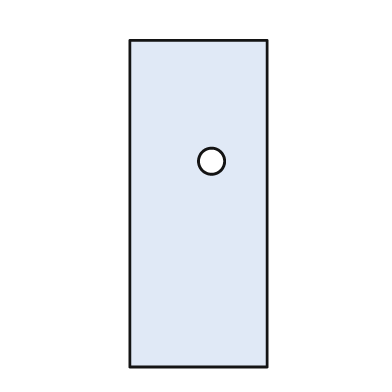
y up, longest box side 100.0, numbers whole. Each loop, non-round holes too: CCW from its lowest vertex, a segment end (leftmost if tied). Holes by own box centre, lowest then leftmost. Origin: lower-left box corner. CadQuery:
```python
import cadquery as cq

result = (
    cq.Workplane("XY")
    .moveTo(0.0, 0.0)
    .lineTo(42.0, 0.0)
    .lineTo(42.0, 100.0)
    .lineTo(0.0, 100.0)
    .close()
    .moveTo(25.0, 63.0)
    .circle(4.0)
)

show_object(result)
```